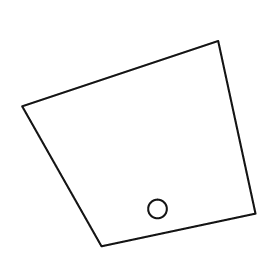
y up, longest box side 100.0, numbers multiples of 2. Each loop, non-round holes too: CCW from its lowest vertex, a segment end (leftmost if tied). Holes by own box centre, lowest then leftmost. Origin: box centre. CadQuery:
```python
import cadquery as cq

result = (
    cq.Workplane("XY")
    .moveTo(-16.0, -44.0)
    .lineTo(50.0, -30.0)
    .lineTo(34.0, 44.0)
    .lineTo(-50.0, 16.0)
    .close()
    .moveTo(8.0, -28.0)
    .circle(4.0)
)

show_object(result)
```